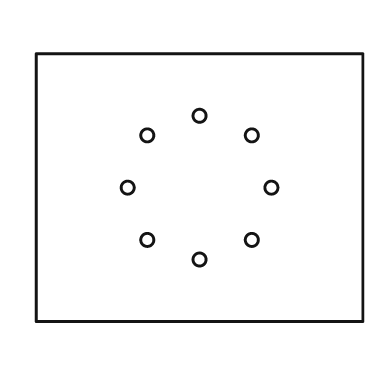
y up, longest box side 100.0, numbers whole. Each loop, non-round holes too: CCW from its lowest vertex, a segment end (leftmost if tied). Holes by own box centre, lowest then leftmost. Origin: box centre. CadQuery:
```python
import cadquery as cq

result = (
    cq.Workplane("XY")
    .moveTo(-50.0, -41.0)
    .lineTo(50.0, -41.0)
    .lineTo(50.0, 41.0)
    .lineTo(-50.0, 41.0)
    .close()
    .moveTo(0.0, -22.0)
    .circle(2.0)
    .moveTo(-16.0, -16.0)
    .circle(2.0)
    .moveTo(16.0, -16.0)
    .circle(2.0)
    .moveTo(-22.0, 0.0)
    .circle(2.0)
    .moveTo(22.0, 0.0)
    .circle(2.0)
    .moveTo(-16.0, 16.0)
    .circle(2.0)
    .moveTo(16.0, 16.0)
    .circle(2.0)
    .moveTo(0.0, 22.0)
    .circle(2.0)
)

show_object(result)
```